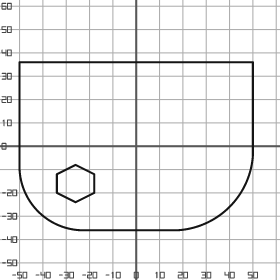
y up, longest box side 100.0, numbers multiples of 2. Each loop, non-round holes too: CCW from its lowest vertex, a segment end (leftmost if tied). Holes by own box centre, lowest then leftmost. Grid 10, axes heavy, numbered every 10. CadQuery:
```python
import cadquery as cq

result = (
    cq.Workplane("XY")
    .moveTo(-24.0, -36.0)
    .lineTo(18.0, -36.0)
    .threePointArc((40.0, -26.0), (50.0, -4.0))
    .lineTo(50.0, 36.0)
    .lineTo(-50.0, 36.0)
    .lineTo(-50.0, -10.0)
    .threePointArc((-42.0, -28.0), (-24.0, -36.0))
    .close()
    .moveTo(-26.0, -24.0)
    .lineTo(-18.0, -20.0)
    .lineTo(-18.0, -12.0)
    .lineTo(-26.0, -8.0)
    .lineTo(-34.0, -12.0)
    .lineTo(-34.0, -20.0)
    .close()
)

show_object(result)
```